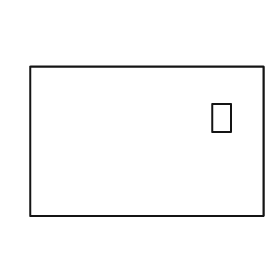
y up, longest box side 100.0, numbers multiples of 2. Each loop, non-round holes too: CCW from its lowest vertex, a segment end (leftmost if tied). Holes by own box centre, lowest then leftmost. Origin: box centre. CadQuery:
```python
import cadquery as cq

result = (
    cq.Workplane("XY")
    .moveTo(-50.0, -32.0)
    .lineTo(50.0, -32.0)
    .lineTo(50.0, 32.0)
    .lineTo(-50.0, 32.0)
    .close()
    .moveTo(28.0, 4.0)
    .lineTo(36.0, 4.0)
    .lineTo(36.0, 16.0)
    .lineTo(28.0, 16.0)
    .close()
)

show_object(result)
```